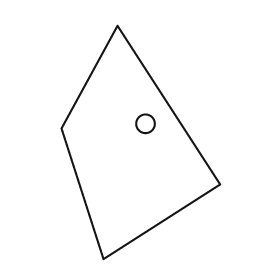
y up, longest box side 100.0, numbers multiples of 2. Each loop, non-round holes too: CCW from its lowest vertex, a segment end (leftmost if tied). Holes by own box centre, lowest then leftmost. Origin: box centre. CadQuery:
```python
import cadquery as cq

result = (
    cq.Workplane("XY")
    .moveTo(-16.0, -50.0)
    .lineTo(34.0, -18.0)
    .lineTo(-10.0, 50.0)
    .lineTo(-34.0, 6.0)
    .close()
    .moveTo(2.0, 8.0)
    .circle(4.0)
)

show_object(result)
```